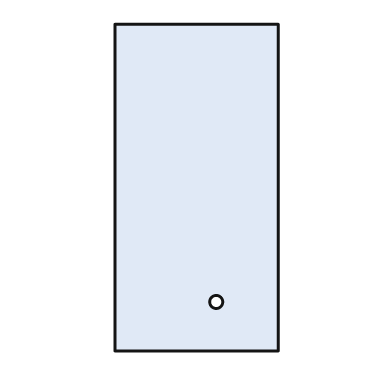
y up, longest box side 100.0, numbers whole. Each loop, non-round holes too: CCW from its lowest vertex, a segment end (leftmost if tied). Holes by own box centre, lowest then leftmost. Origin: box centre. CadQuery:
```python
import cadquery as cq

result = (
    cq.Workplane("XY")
    .moveTo(-25.0, -50.0)
    .lineTo(25.0, -50.0)
    .lineTo(25.0, 50.0)
    .lineTo(-25.0, 50.0)
    .close()
    .moveTo(6.0, -35.0)
    .circle(2.0)
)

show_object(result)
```